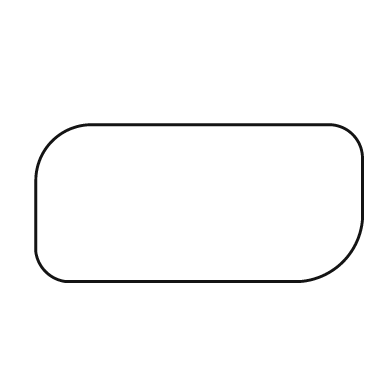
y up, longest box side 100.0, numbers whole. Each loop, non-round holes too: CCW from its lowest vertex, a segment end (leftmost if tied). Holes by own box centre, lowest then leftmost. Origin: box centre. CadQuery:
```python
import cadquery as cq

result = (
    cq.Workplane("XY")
    .moveTo(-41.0, -24.0)
    .lineTo(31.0, -24.0)
    .threePointArc((44.0, -18.0), (50.0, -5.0))
    .lineTo(50.0, 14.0)
    .threePointArc((47.0, 21.0), (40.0, 24.0))
    .lineTo(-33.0, 24.0)
    .threePointArc((-45.0, 19.0), (-50.0, 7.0))
    .lineTo(-50.0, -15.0)
    .threePointArc((-47.0, -21.0), (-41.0, -24.0))
    .close()
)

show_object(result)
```